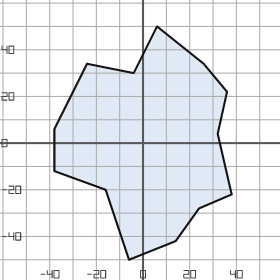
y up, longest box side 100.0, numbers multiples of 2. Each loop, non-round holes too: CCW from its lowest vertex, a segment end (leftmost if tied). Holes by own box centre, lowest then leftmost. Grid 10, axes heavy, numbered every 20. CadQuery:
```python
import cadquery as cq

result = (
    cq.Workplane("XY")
    .moveTo(-6.0, -50.0)
    .lineTo(14.0, -42.0)
    .lineTo(24.0, -28.0)
    .lineTo(38.0, -22.0)
    .lineTo(32.0, 4.0)
    .lineTo(36.0, 22.0)
    .lineTo(26.0, 34.0)
    .lineTo(6.0, 50.0)
    .lineTo(-4.0, 30.0)
    .lineTo(-24.0, 34.0)
    .lineTo(-38.0, 6.0)
    .lineTo(-38.0, -12.0)
    .lineTo(-16.0, -20.0)
    .close()
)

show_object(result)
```